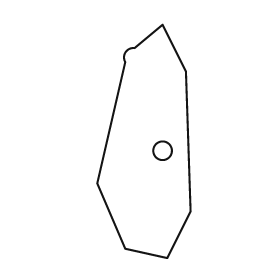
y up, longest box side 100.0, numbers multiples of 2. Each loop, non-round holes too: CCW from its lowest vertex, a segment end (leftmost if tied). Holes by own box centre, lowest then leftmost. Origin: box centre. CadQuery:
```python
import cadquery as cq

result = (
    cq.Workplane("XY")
    .moveTo(10.0, -50.0)
    .lineTo(20.0, -30.0)
    .lineTo(18.0, 30.0)
    .lineTo(8.0, 50.0)
    .lineTo(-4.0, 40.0)
    .threePointArc((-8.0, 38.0), (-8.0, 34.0))
    .lineTo(-20.0, -18.0)
    .lineTo(-8.0, -46.0)
    .close()
    .moveTo(8.0, -4.0)
    .circle(4.0)
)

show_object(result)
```